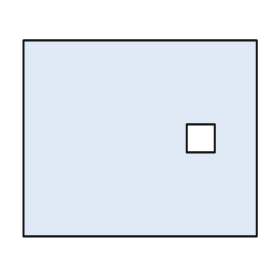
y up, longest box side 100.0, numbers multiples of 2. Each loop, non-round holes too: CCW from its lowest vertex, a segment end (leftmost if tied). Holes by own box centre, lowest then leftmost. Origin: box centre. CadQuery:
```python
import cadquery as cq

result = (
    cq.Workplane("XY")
    .moveTo(-50.0, -42.0)
    .lineTo(50.0, -42.0)
    .lineTo(50.0, 42.0)
    .lineTo(-50.0, 42.0)
    .close()
    .moveTo(20.0, -6.0)
    .lineTo(32.0, -6.0)
    .lineTo(32.0, 6.0)
    .lineTo(20.0, 6.0)
    .close()
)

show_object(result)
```